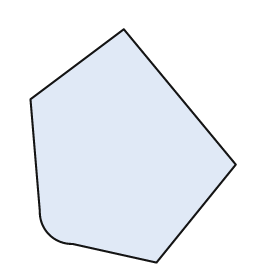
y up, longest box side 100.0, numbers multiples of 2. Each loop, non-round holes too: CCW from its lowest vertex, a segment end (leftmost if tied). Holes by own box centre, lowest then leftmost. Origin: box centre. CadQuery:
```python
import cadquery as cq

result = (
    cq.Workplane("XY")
    .moveTo(10.0, -50.0)
    .lineTo(44.0, -8.0)
    .lineTo(-4.0, 50.0)
    .lineTo(-44.0, 20.0)
    .lineTo(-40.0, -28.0)
    .threePointArc((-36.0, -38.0), (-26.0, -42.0))
    .close()
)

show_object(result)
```